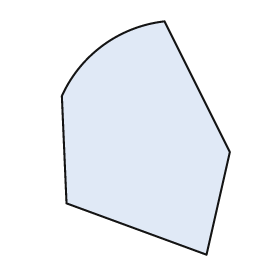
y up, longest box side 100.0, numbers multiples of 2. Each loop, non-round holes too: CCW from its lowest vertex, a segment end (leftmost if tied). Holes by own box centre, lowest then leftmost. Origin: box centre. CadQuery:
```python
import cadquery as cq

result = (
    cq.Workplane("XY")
    .moveTo(26.0, -50.0)
    .lineTo(36.0, -6.0)
    .lineTo(8.0, 50.0)
    .threePointArc((-18.0, 40.0), (-36.0, 18.0))
    .lineTo(-34.0, -28.0)
    .close()
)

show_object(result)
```